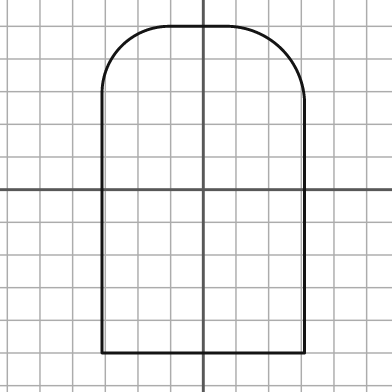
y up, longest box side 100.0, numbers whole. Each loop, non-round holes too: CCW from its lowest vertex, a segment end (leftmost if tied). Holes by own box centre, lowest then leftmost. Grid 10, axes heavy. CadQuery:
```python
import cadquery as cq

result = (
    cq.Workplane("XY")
    .moveTo(-31.0, -50.0)
    .lineTo(31.0, -50.0)
    .lineTo(31.0, 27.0)
    .threePointArc((24.0, 43.0), (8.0, 50.0))
    .lineTo(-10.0, 50.0)
    .threePointArc((-25.0, 44.0), (-31.0, 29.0))
    .close()
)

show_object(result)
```